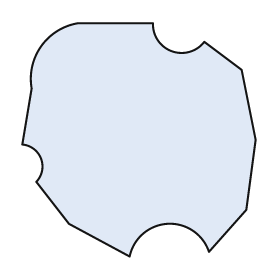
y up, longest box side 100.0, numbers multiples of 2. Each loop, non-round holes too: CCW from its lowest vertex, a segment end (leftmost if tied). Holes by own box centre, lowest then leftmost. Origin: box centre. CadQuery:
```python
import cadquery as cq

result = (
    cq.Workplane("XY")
    .moveTo(-4.0, -50.0)
    .threePointArc((12.0, -36.0), (30.0, -48.0))
    .lineTo(46.0, -30.0)
    .lineTo(50.0, 0.0)
    .lineTo(44.0, 30.0)
    .lineTo(28.0, 42.0)
    .threePointArc((14.0, 38.0), (6.0, 50.0))
    .lineTo(-26.0, 50.0)
    .threePointArc((-42.0, 40.0), (-46.0, 22.0))
    .lineTo(-50.0, -2.0)
    .threePointArc((-42.0, -8.0), (-44.0, -18.0))
    .lineTo(-30.0, -36.0)
    .close()
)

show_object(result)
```